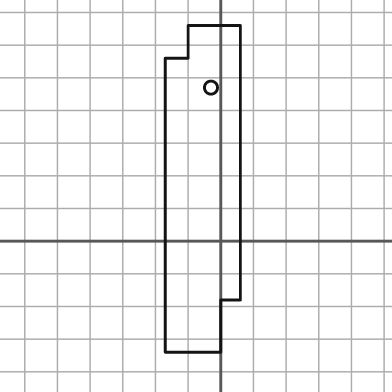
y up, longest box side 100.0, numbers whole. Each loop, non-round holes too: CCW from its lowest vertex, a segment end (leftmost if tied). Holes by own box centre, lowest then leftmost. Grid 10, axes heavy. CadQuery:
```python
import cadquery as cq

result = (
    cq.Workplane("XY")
    .moveTo(-17.0, -34.0)
    .lineTo(0.0, -34.0)
    .lineTo(0.0, -18.0)
    .lineTo(6.0, -18.0)
    .lineTo(6.0, 66.0)
    .lineTo(-10.0, 66.0)
    .lineTo(-10.0, 56.0)
    .lineTo(-17.0, 56.0)
    .close()
    .moveTo(-3.0, 47.0)
    .circle(2.0)
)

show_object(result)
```